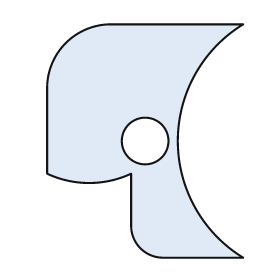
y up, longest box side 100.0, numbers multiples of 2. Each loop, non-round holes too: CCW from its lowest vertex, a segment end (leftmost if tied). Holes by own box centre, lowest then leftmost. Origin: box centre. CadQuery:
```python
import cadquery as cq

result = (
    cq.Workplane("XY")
    .moveTo(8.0, -50.0)
    .lineTo(42.0, -50.0)
    .threePointArc((14.0, 0.0), (42.0, 50.0))
    .lineTo(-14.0, 50.0)
    .threePointArc((-34.0, 42.0), (-42.0, 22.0))
    .lineTo(-42.0, -14.0)
    .threePointArc((-24.0, -18.0), (-6.0, -14.0))
    .lineTo(-6.0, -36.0)
    .threePointArc((-2.0, -46.0), (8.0, -50.0))
    .close()
    .moveTo(0.0, 0.0)
    .circle(10.0)
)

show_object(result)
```